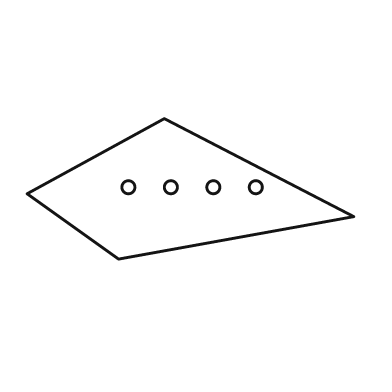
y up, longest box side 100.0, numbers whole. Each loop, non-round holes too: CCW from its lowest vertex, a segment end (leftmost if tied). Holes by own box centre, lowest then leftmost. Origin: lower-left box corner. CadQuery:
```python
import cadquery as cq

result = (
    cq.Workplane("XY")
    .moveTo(28.0, 0.0)
    .lineTo(100.0, 13.0)
    .lineTo(42.0, 43.0)
    .lineTo(0.0, 20.0)
    .close()
    .moveTo(31.0, 22.0)
    .circle(2.0)
    .moveTo(44.0, 22.0)
    .circle(2.0)
    .moveTo(57.0, 22.0)
    .circle(2.0)
    .moveTo(70.0, 22.0)
    .circle(2.0)
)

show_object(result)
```